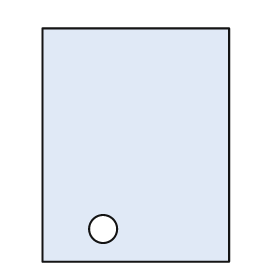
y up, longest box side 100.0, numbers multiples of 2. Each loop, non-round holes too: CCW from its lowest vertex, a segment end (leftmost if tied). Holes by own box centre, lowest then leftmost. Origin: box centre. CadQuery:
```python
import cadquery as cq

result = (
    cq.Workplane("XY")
    .moveTo(-40.0, -50.0)
    .lineTo(40.0, -50.0)
    .lineTo(40.0, 50.0)
    .lineTo(-40.0, 50.0)
    .close()
    .moveTo(-14.0, -36.0)
    .circle(6.0)
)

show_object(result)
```